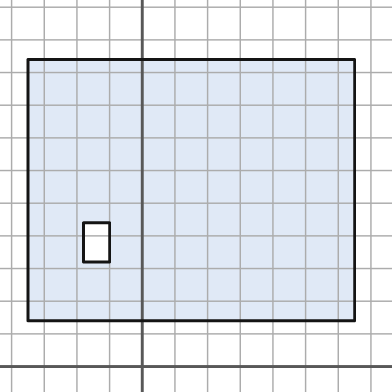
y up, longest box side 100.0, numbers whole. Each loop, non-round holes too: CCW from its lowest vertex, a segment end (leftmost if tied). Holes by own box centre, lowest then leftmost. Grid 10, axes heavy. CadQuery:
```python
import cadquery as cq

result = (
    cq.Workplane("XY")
    .moveTo(-35.0, 14.0)
    .lineTo(65.0, 14.0)
    .lineTo(65.0, 94.0)
    .lineTo(-35.0, 94.0)
    .close()
    .moveTo(-18.0, 32.0)
    .lineTo(-10.0, 32.0)
    .lineTo(-10.0, 44.0)
    .lineTo(-18.0, 44.0)
    .close()
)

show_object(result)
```